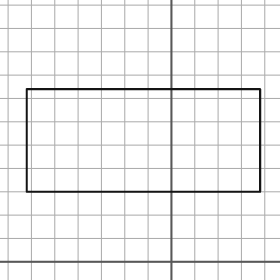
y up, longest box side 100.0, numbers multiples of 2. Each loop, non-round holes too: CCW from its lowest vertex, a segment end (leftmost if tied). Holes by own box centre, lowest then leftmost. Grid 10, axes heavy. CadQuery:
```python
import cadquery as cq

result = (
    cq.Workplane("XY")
    .moveTo(-62.0, 30.0)
    .lineTo(38.0, 30.0)
    .lineTo(38.0, 74.0)
    .lineTo(-62.0, 74.0)
    .close()
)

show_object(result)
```